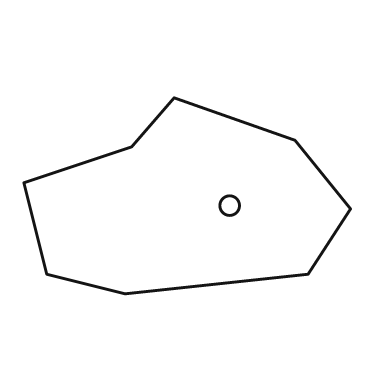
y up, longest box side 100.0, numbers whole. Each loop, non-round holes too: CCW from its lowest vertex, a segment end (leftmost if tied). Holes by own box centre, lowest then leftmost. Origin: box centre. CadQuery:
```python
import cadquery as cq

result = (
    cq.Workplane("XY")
    .moveTo(-19.0, -30.0)
    .lineTo(37.0, -24.0)
    .lineTo(50.0, -4.0)
    .lineTo(33.0, 17.0)
    .lineTo(-4.0, 30.0)
    .lineTo(-17.0, 15.0)
    .lineTo(-50.0, 4.0)
    .lineTo(-43.0, -24.0)
    .close()
    .moveTo(13.0, -3.0)
    .circle(3.0)
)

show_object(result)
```